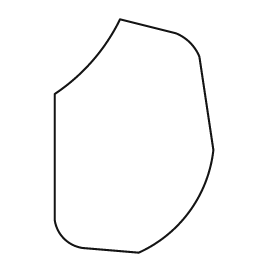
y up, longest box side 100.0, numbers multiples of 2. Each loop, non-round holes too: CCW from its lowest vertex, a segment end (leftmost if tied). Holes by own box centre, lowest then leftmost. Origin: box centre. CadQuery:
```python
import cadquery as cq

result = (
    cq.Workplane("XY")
    .moveTo(2.0, -50.0)
    .threePointArc((24.0, -32.0), (34.0, -6.0))
    .lineTo(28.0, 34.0)
    .threePointArc((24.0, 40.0), (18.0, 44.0))
    .lineTo(-6.0, 50.0)
    .threePointArc((-18.0, 32.0), (-34.0, 18.0))
    .lineTo(-34.0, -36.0)
    .threePointArc((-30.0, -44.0), (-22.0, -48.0))
    .close()
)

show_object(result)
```